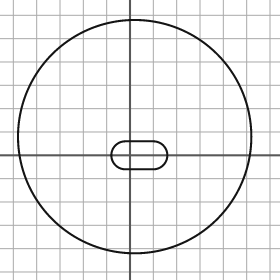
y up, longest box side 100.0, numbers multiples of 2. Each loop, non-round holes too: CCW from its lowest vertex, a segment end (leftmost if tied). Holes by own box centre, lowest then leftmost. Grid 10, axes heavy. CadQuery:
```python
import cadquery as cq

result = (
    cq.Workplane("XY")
    .moveTo(2.0, 8.0)
    .circle(50.0)
    .moveTo(-2.0, -6.0)
    .lineTo(10.0, -6.0)
    .threePointArc((16.0, 0.0), (10.0, 6.0))
    .lineTo(-2.0, 6.0)
    .threePointArc((-8.0, 0.0), (-2.0, -6.0))
    .close()
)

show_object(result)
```